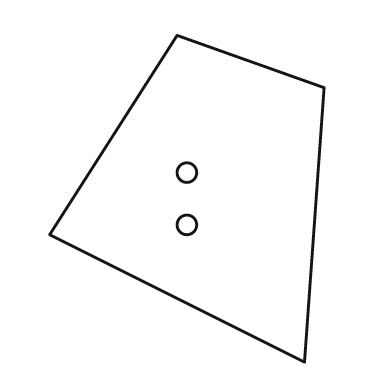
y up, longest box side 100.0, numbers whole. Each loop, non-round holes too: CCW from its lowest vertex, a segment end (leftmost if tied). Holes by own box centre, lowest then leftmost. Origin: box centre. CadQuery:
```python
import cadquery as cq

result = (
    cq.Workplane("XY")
    .moveTo(36.0, -50.0)
    .lineTo(42.0, 34.0)
    .lineTo(-3.0, 50.0)
    .lineTo(-42.0, -11.0)
    .close()
    .moveTo(0.0, -8.0)
    .circle(3.0)
    .moveTo(0.0, 8.0)
    .circle(3.0)
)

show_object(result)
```